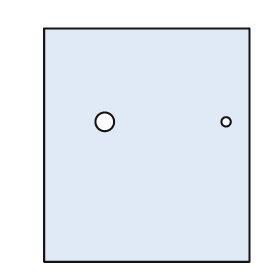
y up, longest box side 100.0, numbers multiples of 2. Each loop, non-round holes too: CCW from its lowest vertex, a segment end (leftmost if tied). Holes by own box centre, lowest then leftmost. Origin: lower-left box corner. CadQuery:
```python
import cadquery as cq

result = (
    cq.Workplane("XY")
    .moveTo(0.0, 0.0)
    .lineTo(88.0, 0.0)
    .lineTo(88.0, 100.0)
    .lineTo(0.0, 100.0)
    .close()
    .moveTo(26.0, 60.0)
    .circle(4.0)
    .moveTo(78.0, 60.0)
    .circle(2.0)
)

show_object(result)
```